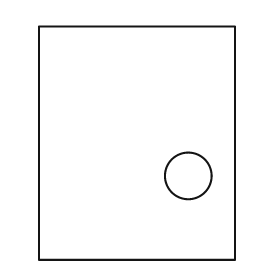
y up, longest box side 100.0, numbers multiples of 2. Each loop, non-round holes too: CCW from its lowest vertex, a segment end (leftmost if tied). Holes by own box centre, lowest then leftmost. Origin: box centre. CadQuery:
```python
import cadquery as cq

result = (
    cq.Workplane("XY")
    .moveTo(-42.0, -50.0)
    .lineTo(42.0, -50.0)
    .lineTo(42.0, 50.0)
    .lineTo(-42.0, 50.0)
    .close()
    .moveTo(22.0, -14.0)
    .circle(10.0)
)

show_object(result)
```